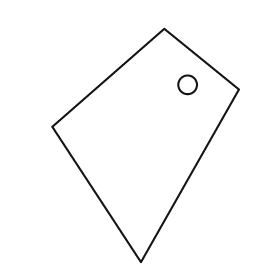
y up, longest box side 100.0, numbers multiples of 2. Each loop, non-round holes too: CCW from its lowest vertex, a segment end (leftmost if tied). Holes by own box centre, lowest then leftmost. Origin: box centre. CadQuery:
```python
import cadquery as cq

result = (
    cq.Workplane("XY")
    .moveTo(-2.0, -50.0)
    .lineTo(40.0, 24.0)
    .lineTo(8.0, 50.0)
    .lineTo(-40.0, 8.0)
    .close()
    .moveTo(18.0, 26.0)
    .circle(4.0)
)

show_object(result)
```